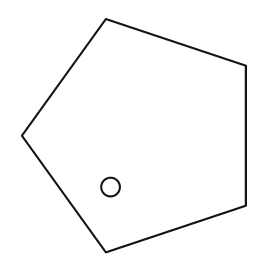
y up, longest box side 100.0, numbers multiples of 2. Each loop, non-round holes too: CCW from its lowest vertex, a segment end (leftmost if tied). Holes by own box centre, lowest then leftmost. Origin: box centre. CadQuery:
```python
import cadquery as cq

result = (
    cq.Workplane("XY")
    .moveTo(-12.0, -50.0)
    .lineTo(48.0, -30.0)
    .lineTo(48.0, 30.0)
    .lineTo(-12.0, 50.0)
    .lineTo(-48.0, 0.0)
    .close()
    .moveTo(-10.0, -22.0)
    .circle(4.0)
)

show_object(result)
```